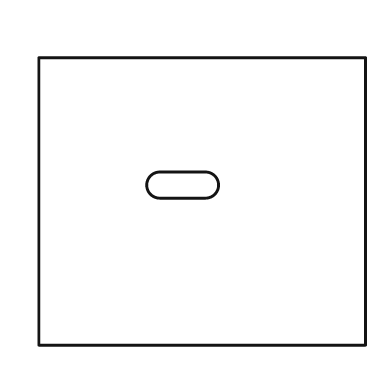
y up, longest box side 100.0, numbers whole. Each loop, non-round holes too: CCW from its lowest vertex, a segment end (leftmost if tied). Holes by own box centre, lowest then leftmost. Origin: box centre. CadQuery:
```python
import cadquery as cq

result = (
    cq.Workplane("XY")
    .moveTo(-50.0, -44.0)
    .lineTo(50.0, -44.0)
    .lineTo(50.0, 44.0)
    .lineTo(-50.0, 44.0)
    .close()
    .moveTo(-13.0, 1.0)
    .lineTo(1.0, 1.0)
    .threePointArc((5.0, 5.0), (1.0, 9.0))
    .lineTo(-13.0, 9.0)
    .threePointArc((-17.0, 5.0), (-13.0, 1.0))
    .close()
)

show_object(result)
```